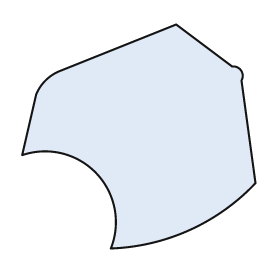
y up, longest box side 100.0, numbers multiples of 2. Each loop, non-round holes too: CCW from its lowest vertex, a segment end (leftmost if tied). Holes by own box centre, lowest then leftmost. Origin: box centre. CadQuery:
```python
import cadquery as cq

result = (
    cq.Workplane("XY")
    .moveTo(-12.0, -48.0)
    .threePointArc((22.0, -40.0), (50.0, -20.0))
    .lineTo(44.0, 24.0)
    .threePointArc((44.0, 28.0), (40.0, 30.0))
    .lineTo(16.0, 48.0)
    .lineTo(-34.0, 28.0)
    .threePointArc((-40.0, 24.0), (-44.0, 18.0))
    .lineTo(-50.0, -8.0)
    .threePointArc((-18.0, -16.0), (-12.0, -48.0))
    .close()
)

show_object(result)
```